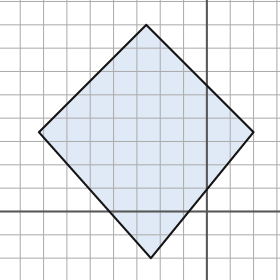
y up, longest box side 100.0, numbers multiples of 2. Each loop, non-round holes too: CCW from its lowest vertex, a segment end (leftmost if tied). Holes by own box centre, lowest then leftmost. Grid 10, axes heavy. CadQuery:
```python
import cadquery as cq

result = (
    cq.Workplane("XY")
    .moveTo(-24.0, -20.0)
    .lineTo(20.0, 34.0)
    .lineTo(-26.0, 80.0)
    .lineTo(-72.0, 34.0)
    .close()
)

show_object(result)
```